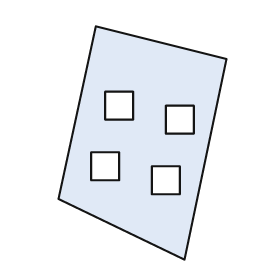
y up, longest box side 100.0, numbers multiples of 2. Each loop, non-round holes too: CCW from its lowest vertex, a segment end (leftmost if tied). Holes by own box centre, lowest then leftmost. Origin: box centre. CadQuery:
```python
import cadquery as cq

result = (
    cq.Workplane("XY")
    .moveTo(18.0, -50.0)
    .lineTo(36.0, 36.0)
    .lineTo(-20.0, 50.0)
    .lineTo(-36.0, -24.0)
    .close()
    .moveTo(4.0, -22.0)
    .lineTo(16.0, -22.0)
    .lineTo(16.0, -10.0)
    .lineTo(4.0, -10.0)
    .close()
    .moveTo(-22.0, -16.0)
    .lineTo(-10.0, -16.0)
    .lineTo(-10.0, -4.0)
    .lineTo(-22.0, -4.0)
    .close()
    .moveTo(10.0, 4.0)
    .lineTo(22.0, 4.0)
    .lineTo(22.0, 16.0)
    .lineTo(10.0, 16.0)
    .close()
    .moveTo(-16.0, 10.0)
    .lineTo(-4.0, 10.0)
    .lineTo(-4.0, 22.0)
    .lineTo(-16.0, 22.0)
    .close()
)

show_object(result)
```